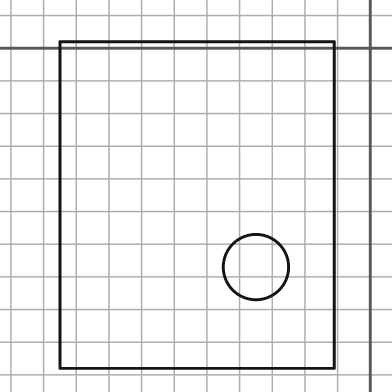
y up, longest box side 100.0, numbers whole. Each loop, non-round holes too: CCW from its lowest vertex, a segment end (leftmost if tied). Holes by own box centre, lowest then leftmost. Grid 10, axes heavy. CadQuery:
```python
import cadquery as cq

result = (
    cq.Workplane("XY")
    .moveTo(-95.0, -98.0)
    .lineTo(-11.0, -98.0)
    .lineTo(-11.0, 2.0)
    .lineTo(-95.0, 2.0)
    .close()
    .moveTo(-35.0, -67.0)
    .circle(10.0)
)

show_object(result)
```